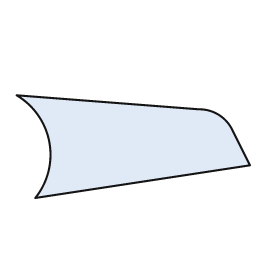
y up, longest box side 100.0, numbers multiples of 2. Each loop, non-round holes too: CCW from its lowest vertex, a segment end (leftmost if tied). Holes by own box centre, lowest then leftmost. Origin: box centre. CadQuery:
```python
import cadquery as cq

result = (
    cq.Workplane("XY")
    .moveTo(-42.0, -22.0)
    .lineTo(50.0, -8.0)
    .lineTo(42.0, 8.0)
    .threePointArc((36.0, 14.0), (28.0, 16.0))
    .lineTo(-50.0, 22.0)
    .threePointArc((-36.0, 2.0), (-42.0, -22.0))
    .close()
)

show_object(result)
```